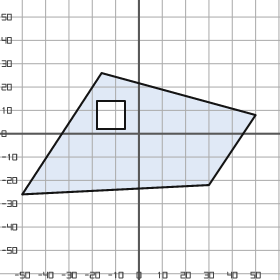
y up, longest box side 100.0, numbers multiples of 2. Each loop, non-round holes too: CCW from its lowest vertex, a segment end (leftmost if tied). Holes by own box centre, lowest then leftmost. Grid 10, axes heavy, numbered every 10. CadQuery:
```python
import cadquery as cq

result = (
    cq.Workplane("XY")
    .moveTo(-50.0, -26.0)
    .lineTo(30.0, -22.0)
    .lineTo(50.0, 8.0)
    .lineTo(-16.0, 26.0)
    .close()
    .moveTo(-18.0, 2.0)
    .lineTo(-6.0, 2.0)
    .lineTo(-6.0, 14.0)
    .lineTo(-18.0, 14.0)
    .close()
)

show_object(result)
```